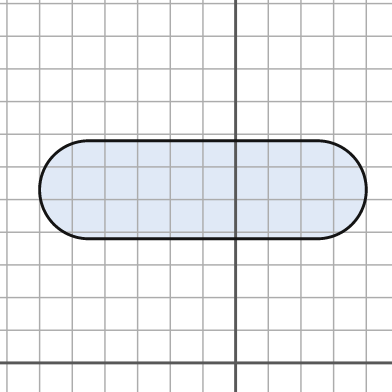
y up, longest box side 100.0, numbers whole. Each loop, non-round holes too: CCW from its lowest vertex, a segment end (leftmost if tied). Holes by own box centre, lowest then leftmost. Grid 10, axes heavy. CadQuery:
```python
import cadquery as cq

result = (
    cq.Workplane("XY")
    .moveTo(-45.0, 38.0)
    .lineTo(25.0, 38.0)
    .threePointArc((40.0, 53.0), (25.0, 68.0))
    .lineTo(-45.0, 68.0)
    .threePointArc((-60.0, 53.0), (-45.0, 38.0))
    .close()
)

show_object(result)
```